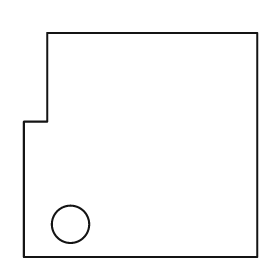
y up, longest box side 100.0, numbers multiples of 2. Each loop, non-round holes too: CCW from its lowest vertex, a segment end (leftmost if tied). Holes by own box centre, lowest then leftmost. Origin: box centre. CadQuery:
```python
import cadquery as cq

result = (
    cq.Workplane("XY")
    .moveTo(-50.0, -48.0)
    .lineTo(50.0, -48.0)
    .lineTo(50.0, 48.0)
    .lineTo(-40.0, 48.0)
    .lineTo(-40.0, 10.0)
    .lineTo(-50.0, 10.0)
    .close()
    .moveTo(-30.0, -34.0)
    .circle(8.0)
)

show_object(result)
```